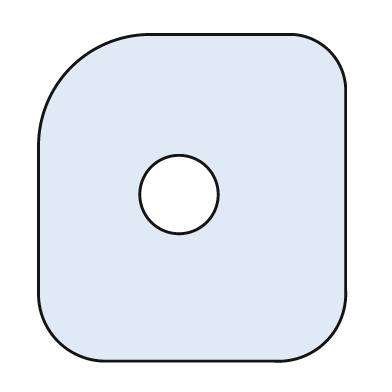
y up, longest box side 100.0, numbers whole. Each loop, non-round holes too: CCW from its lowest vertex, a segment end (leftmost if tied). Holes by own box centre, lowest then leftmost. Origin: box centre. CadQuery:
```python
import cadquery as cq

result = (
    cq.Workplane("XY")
    .moveTo(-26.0, -50.0)
    .lineTo(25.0, -50.0)
    .threePointArc((41.0, -44.0), (47.0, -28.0))
    .lineTo(47.0, 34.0)
    .threePointArc((42.0, 45.0), (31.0, 50.0))
    .lineTo(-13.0, 50.0)
    .threePointArc((-37.0, 40.0), (-47.0, 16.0))
    .lineTo(-47.0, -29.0)
    .threePointArc((-41.0, -44.0), (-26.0, -50.0))
    .close()
    .moveTo(-4.0, 1.0)
    .circle(12.0)
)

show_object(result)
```